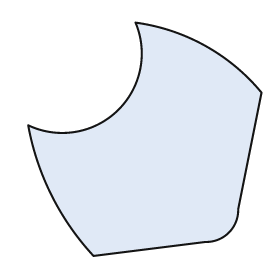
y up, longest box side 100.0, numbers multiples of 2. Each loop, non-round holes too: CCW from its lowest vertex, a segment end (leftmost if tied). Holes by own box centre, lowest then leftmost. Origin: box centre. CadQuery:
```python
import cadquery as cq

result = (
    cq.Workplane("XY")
    .moveTo(-22.0, -50.0)
    .lineTo(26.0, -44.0)
    .threePointArc((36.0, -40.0), (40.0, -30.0))
    .lineTo(50.0, 20.0)
    .threePointArc((26.0, 40.0), (-4.0, 50.0))
    .threePointArc((-12.0, 12.0), (-50.0, 6.0))
    .threePointArc((-40.0, -24.0), (-22.0, -50.0))
    .close()
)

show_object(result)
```